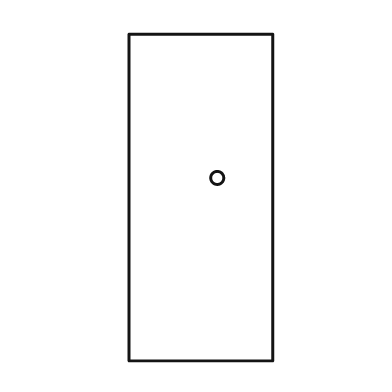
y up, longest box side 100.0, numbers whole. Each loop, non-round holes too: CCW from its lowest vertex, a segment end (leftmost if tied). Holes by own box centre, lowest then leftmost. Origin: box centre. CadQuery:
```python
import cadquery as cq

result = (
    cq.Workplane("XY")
    .moveTo(-22.0, -50.0)
    .lineTo(22.0, -50.0)
    .lineTo(22.0, 50.0)
    .lineTo(-22.0, 50.0)
    .close()
    .moveTo(5.0, 6.0)
    .circle(2.0)
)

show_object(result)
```